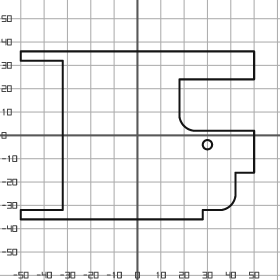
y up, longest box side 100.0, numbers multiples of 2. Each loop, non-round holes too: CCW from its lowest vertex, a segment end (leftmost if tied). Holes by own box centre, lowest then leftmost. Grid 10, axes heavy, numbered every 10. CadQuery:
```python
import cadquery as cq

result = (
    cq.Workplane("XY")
    .moveTo(-50.0, -36.0)
    .lineTo(28.0, -36.0)
    .lineTo(28.0, -32.0)
    .lineTo(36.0, -32.0)
    .threePointArc((40.0, -30.0), (42.0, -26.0))
    .lineTo(42.0, -16.0)
    .lineTo(50.0, -16.0)
    .lineTo(50.0, 2.0)
    .lineTo(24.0, 2.0)
    .threePointArc((20.0, 4.0), (18.0, 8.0))
    .lineTo(18.0, 24.0)
    .lineTo(50.0, 24.0)
    .lineTo(50.0, 36.0)
    .lineTo(-50.0, 36.0)
    .lineTo(-50.0, 32.0)
    .lineTo(-32.0, 32.0)
    .lineTo(-32.0, -32.0)
    .lineTo(-50.0, -32.0)
    .close()
    .moveTo(30.0, -4.0)
    .circle(2.0)
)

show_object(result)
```